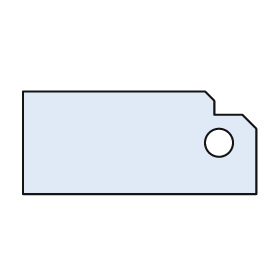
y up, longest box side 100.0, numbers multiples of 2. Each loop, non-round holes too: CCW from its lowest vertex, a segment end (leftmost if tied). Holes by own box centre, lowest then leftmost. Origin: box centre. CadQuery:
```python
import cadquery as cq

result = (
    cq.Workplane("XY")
    .moveTo(-50.0, -22.0)
    .lineTo(50.0, -22.0)
    .lineTo(50.0, 6.0)
    .lineTo(44.0, 12.0)
    .lineTo(32.0, 12.0)
    .lineTo(32.0, 18.0)
    .lineTo(28.0, 22.0)
    .lineTo(-50.0, 22.0)
    .close()
    .moveTo(34.0, 0.0)
    .circle(6.0)
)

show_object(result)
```